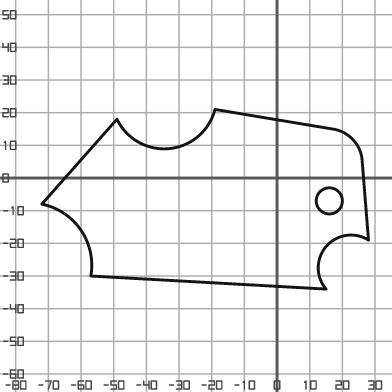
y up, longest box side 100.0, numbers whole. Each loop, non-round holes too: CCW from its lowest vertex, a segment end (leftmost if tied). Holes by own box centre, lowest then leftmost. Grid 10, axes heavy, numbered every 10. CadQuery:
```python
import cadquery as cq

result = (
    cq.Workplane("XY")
    .moveTo(15.0, -34.0)
    .threePointArc((15.0, -21.0), (28.0, -19.0))
    .lineTo(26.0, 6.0)
    .threePointArc((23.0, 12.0), (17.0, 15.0))
    .lineTo(-19.0, 21.0)
    .threePointArc((-33.0, 9.0), (-49.0, 18.0))
    .lineTo(-72.0, -8.0)
    .threePointArc((-60.0, -16.0), (-57.0, -30.0))
    .close()
    .moveTo(16.0, -7.0)
    .circle(4.0)
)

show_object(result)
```